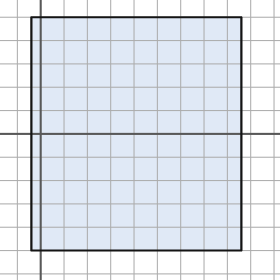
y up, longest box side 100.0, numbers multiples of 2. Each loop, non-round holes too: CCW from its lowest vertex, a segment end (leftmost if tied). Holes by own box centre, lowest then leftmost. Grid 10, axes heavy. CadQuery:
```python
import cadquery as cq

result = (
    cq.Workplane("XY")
    .moveTo(-4.0, -50.0)
    .lineTo(86.0, -50.0)
    .lineTo(86.0, 50.0)
    .lineTo(-4.0, 50.0)
    .close()
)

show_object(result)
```